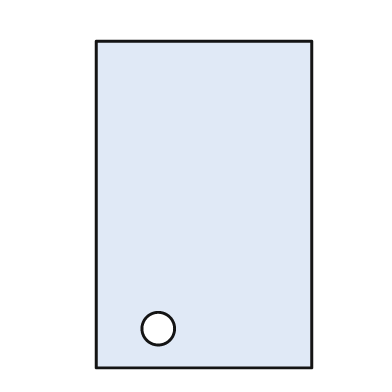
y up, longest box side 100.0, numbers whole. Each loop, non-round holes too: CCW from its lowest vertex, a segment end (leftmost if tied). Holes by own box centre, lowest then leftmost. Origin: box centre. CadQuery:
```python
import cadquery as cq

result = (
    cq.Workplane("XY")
    .moveTo(-33.0, -50.0)
    .lineTo(33.0, -50.0)
    .lineTo(33.0, 50.0)
    .lineTo(-33.0, 50.0)
    .close()
    .moveTo(-14.0, -38.0)
    .circle(5.0)
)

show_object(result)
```